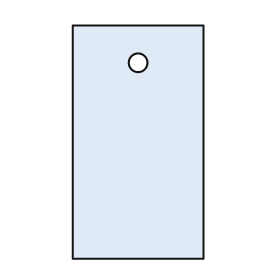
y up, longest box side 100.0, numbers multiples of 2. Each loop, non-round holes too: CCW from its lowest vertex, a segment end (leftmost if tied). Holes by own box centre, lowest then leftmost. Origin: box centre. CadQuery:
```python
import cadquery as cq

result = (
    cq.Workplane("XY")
    .moveTo(-28.0, -50.0)
    .lineTo(28.0, -50.0)
    .lineTo(28.0, 50.0)
    .lineTo(-28.0, 50.0)
    .close()
    .moveTo(0.0, 34.0)
    .circle(4.0)
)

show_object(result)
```